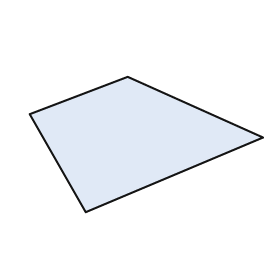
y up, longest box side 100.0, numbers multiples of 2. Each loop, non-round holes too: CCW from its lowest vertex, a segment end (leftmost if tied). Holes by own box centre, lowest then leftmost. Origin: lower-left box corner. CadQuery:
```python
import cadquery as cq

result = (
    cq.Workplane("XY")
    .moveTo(24.0, 0.0)
    .lineTo(100.0, 32.0)
    .lineTo(42.0, 58.0)
    .lineTo(0.0, 42.0)
    .close()
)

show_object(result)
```